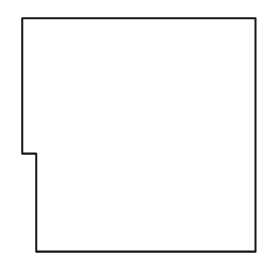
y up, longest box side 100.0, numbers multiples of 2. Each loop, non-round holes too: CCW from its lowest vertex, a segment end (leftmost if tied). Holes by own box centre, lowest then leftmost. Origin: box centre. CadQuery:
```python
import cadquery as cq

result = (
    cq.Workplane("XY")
    .moveTo(-44.0, -50.0)
    .lineTo(50.0, -50.0)
    .lineTo(50.0, 50.0)
    .lineTo(-50.0, 50.0)
    .lineTo(-50.0, -8.0)
    .lineTo(-44.0, -8.0)
    .close()
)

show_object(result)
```